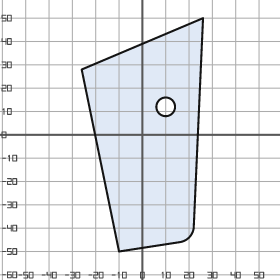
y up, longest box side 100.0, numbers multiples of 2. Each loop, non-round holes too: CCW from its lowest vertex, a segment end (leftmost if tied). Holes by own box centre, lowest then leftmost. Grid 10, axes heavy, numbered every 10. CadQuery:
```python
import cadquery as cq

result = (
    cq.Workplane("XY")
    .moveTo(-10.0, -50.0)
    .lineTo(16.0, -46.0)
    .threePointArc((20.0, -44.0), (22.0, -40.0))
    .lineTo(26.0, 50.0)
    .lineTo(-26.0, 28.0)
    .close()
    .moveTo(10.0, 12.0)
    .circle(4.0)
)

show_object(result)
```